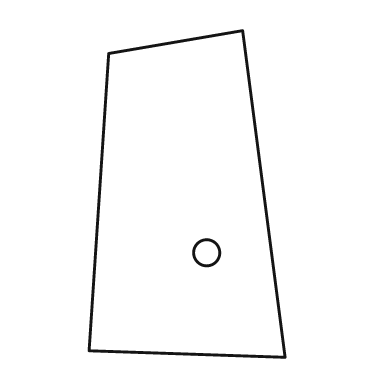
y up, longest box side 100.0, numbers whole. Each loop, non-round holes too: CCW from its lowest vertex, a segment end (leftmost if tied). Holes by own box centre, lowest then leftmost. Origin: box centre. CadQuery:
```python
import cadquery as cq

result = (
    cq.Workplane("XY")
    .moveTo(30.0, -50.0)
    .lineTo(17.0, 50.0)
    .lineTo(-24.0, 43.0)
    .lineTo(-30.0, -48.0)
    .close()
    .moveTo(6.0, -18.0)
    .circle(4.0)
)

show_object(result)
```